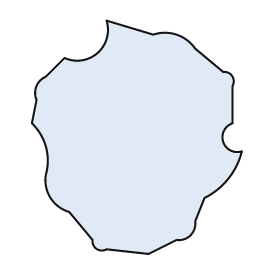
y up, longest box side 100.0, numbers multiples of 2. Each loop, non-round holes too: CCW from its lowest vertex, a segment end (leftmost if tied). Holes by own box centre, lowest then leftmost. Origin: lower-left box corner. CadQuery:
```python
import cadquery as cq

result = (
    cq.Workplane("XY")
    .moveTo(50.0, 0.0)
    .lineTo(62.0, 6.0)
    .threePointArc((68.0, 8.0), (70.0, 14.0))
    .lineTo(74.0, 24.0)
    .threePointArc((84.0, 32.0), (90.0, 44.0))
    .threePointArc((82.0, 48.0), (86.0, 56.0))
    .lineTo(86.0, 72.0)
    .threePointArc((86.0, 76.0), (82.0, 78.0))
    .lineTo(70.0, 88.0)
    .threePointArc((62.0, 94.0), (52.0, 94.0))
    .lineTo(32.0, 100.0)
    .threePointArc((28.0, 86.0), (14.0, 84.0))
    .lineTo(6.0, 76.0)
    .threePointArc((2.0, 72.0), (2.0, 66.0))
    .lineTo(0.0, 56.0)
    .threePointArc((6.0, 46.0), (6.0, 34.0))
    .threePointArc((8.0, 24.0), (16.0, 18.0))
    .lineTo(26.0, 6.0)
    .threePointArc((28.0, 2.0), (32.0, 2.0))
    .close()
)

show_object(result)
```